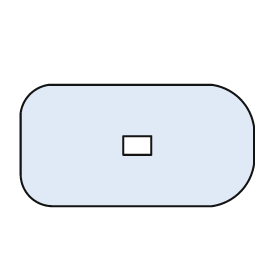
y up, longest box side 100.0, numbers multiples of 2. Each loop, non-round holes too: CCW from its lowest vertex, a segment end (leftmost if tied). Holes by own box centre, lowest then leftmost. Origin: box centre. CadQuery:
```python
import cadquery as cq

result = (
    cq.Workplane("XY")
    .moveTo(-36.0, -26.0)
    .lineTo(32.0, -26.0)
    .threePointArc((44.0, -20.0), (50.0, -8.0))
    .lineTo(50.0, 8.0)
    .threePointArc((44.0, 20.0), (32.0, 26.0))
    .lineTo(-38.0, 26.0)
    .threePointArc((-46.0, 22.0), (-50.0, 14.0))
    .lineTo(-50.0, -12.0)
    .threePointArc((-46.0, -22.0), (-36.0, -26.0))
    .close()
    .moveTo(-6.0, -4.0)
    .lineTo(6.0, -4.0)
    .lineTo(6.0, 4.0)
    .lineTo(-6.0, 4.0)
    .close()
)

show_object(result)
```